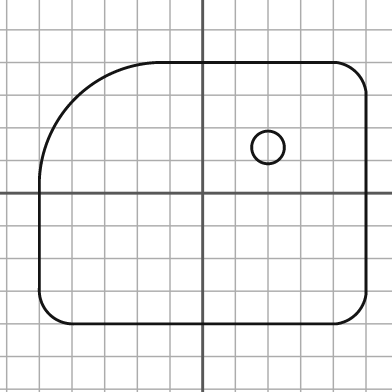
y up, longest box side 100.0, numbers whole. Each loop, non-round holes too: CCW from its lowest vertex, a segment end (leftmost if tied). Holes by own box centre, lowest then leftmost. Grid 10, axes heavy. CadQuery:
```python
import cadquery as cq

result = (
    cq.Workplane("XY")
    .moveTo(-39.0, -40.0)
    .lineTo(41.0, -40.0)
    .threePointArc((47.0, -37.0), (50.0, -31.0))
    .lineTo(50.0, 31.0)
    .threePointArc((47.0, 37.0), (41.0, 40.0))
    .lineTo(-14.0, 40.0)
    .threePointArc((-39.0, 29.0), (-50.0, 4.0))
    .lineTo(-50.0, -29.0)
    .threePointArc((-47.0, -37.0), (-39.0, -40.0))
    .close()
    .moveTo(20.0, 14.0)
    .circle(5.0)
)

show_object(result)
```